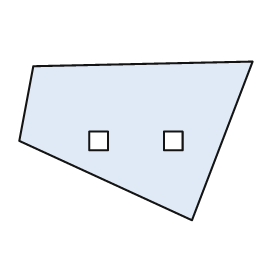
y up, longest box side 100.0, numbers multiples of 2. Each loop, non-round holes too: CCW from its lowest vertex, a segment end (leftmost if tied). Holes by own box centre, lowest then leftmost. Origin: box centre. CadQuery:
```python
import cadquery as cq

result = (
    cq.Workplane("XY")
    .moveTo(24.0, -34.0)
    .lineTo(50.0, 34.0)
    .lineTo(-44.0, 32.0)
    .lineTo(-50.0, 0.0)
    .close()
    .moveTo(-20.0, -4.0)
    .lineTo(-12.0, -4.0)
    .lineTo(-12.0, 4.0)
    .lineTo(-20.0, 4.0)
    .close()
    .moveTo(12.0, -4.0)
    .lineTo(20.0, -4.0)
    .lineTo(20.0, 4.0)
    .lineTo(12.0, 4.0)
    .close()
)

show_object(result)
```